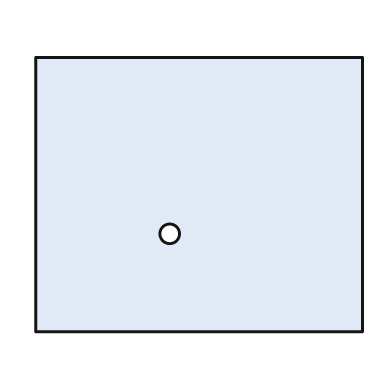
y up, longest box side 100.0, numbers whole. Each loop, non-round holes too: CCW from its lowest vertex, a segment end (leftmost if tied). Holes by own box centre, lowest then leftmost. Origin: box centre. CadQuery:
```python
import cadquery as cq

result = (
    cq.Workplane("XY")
    .moveTo(-50.0, -42.0)
    .lineTo(50.0, -42.0)
    .lineTo(50.0, 42.0)
    .lineTo(-50.0, 42.0)
    .close()
    .moveTo(-9.0, -12.0)
    .circle(3.0)
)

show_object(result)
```